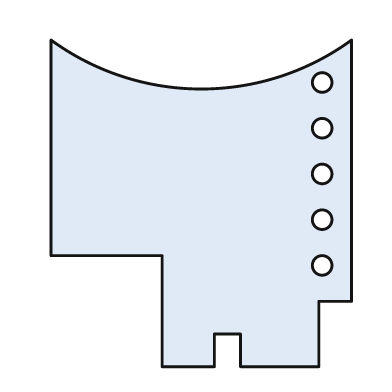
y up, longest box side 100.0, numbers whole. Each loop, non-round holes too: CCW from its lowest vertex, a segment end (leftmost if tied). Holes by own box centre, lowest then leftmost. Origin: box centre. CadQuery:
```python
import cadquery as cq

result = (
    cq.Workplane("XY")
    .moveTo(-12.0, -50.0)
    .lineTo(4.0, -50.0)
    .lineTo(4.0, -40.0)
    .lineTo(12.0, -40.0)
    .lineTo(12.0, -50.0)
    .lineTo(36.0, -50.0)
    .lineTo(36.0, -30.0)
    .lineTo(46.0, -30.0)
    .lineTo(46.0, 50.0)
    .threePointArc((0.0, 35.0), (-46.0, 50.0))
    .lineTo(-46.0, -16.0)
    .lineTo(-12.0, -16.0)
    .close()
    .moveTo(37.0, -19.0)
    .circle(3.0)
    .moveTo(37.0, -5.0)
    .circle(3.0)
    .moveTo(37.0, 9.0)
    .circle(3.0)
    .moveTo(37.0, 23.0)
    .circle(3.0)
    .moveTo(37.0, 37.0)
    .circle(3.0)
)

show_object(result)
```